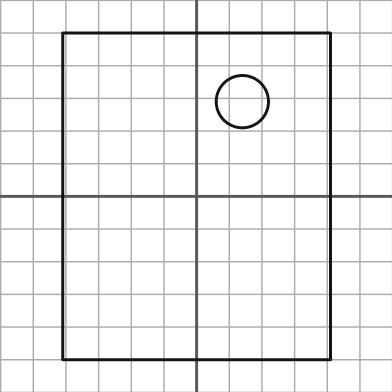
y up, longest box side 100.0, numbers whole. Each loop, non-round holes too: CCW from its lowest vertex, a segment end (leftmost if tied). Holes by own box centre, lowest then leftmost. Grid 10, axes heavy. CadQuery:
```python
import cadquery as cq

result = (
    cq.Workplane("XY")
    .moveTo(-41.0, -50.0)
    .lineTo(41.0, -50.0)
    .lineTo(41.0, 50.0)
    .lineTo(-41.0, 50.0)
    .close()
    .moveTo(14.0, 29.0)
    .circle(8.0)
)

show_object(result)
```